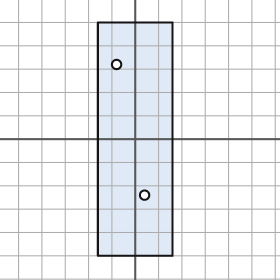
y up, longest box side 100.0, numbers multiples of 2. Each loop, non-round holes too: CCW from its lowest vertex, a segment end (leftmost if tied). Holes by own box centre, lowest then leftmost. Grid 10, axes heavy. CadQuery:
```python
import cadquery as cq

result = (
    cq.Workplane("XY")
    .moveTo(-16.0, -50.0)
    .lineTo(16.0, -50.0)
    .lineTo(16.0, 50.0)
    .lineTo(-16.0, 50.0)
    .close()
    .moveTo(4.0, -24.0)
    .circle(2.0)
    .moveTo(-8.0, 32.0)
    .circle(2.0)
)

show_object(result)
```